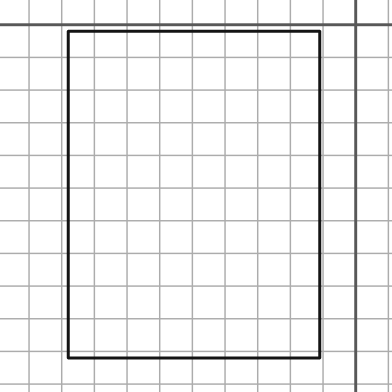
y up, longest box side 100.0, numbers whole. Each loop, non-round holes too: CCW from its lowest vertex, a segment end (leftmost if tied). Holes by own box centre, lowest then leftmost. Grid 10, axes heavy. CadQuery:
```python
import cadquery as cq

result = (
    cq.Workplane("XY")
    .moveTo(-88.0, -102.0)
    .lineTo(-11.0, -102.0)
    .lineTo(-11.0, -2.0)
    .lineTo(-88.0, -2.0)
    .close()
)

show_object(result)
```